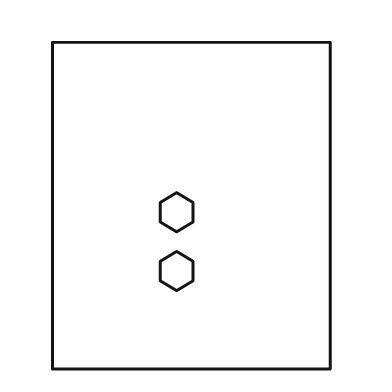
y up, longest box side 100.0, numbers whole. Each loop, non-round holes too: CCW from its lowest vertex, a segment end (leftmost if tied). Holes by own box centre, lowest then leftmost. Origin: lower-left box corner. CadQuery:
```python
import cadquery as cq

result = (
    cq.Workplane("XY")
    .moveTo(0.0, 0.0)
    .lineTo(85.0, 0.0)
    .lineTo(85.0, 100.0)
    .lineTo(0.0, 100.0)
    .close()
    .moveTo(38.0, 24.0)
    .lineTo(43.0, 27.0)
    .lineTo(43.0, 33.0)
    .lineTo(38.0, 36.0)
    .lineTo(33.0, 33.0)
    .lineTo(33.0, 27.0)
    .close()
    .moveTo(38.0, 42.0)
    .lineTo(43.0, 45.0)
    .lineTo(43.0, 51.0)
    .lineTo(38.0, 54.0)
    .lineTo(33.0, 51.0)
    .lineTo(33.0, 45.0)
    .close()
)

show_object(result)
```